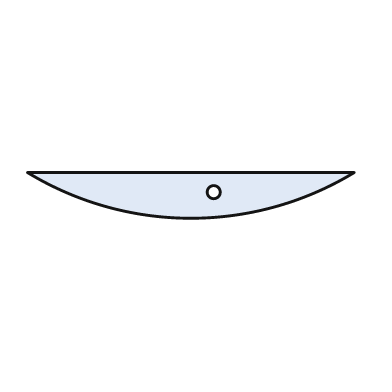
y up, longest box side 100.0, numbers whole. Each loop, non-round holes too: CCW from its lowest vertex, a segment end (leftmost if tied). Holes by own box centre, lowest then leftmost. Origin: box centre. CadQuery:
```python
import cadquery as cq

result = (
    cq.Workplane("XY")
    .moveTo(-50.0, 7.0)
    .threePointArc((0.0, -7.0), (50.0, 7.0))
    .close()
    .moveTo(7.0, 1.0)
    .circle(2.0)
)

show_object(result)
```